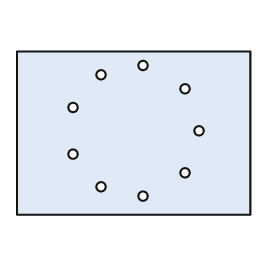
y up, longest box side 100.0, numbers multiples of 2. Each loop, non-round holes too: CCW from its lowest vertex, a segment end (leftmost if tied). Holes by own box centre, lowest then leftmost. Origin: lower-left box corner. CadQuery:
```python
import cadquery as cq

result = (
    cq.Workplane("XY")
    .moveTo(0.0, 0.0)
    .lineTo(100.0, 0.0)
    .lineTo(100.0, 70.0)
    .lineTo(0.0, 70.0)
    .close()
    .moveTo(54.0, 8.0)
    .circle(2.0)
    .moveTo(36.0, 12.0)
    .circle(2.0)
    .moveTo(72.0, 18.0)
    .circle(2.0)
    .moveTo(24.0, 26.0)
    .circle(2.0)
    .moveTo(78.0, 36.0)
    .circle(2.0)
    .moveTo(24.0, 46.0)
    .circle(2.0)
    .moveTo(72.0, 54.0)
    .circle(2.0)
    .moveTo(36.0, 60.0)
    .circle(2.0)
    .moveTo(54.0, 64.0)
    .circle(2.0)
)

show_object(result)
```